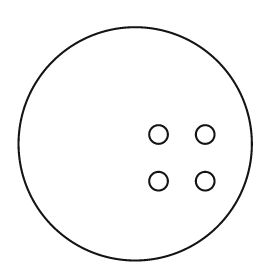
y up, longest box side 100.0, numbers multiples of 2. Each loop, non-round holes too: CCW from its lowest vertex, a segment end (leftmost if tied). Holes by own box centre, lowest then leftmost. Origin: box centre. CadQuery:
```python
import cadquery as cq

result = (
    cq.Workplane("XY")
    .moveTo(0.0, 0.0)
    .circle(50.0)
    .moveTo(10.0, -16.0)
    .circle(4.0)
    .moveTo(30.0, -16.0)
    .circle(4.0)
    .moveTo(10.0, 4.0)
    .circle(4.0)
    .moveTo(30.0, 4.0)
    .circle(4.0)
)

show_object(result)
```